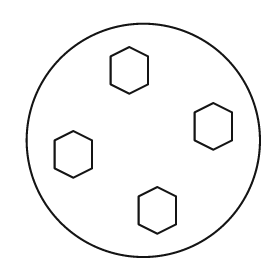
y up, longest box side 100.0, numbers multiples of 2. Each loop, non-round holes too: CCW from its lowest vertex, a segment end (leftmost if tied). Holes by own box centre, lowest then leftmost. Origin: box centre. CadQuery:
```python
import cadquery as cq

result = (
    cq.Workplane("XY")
    .moveTo(0.0, 0.0)
    .circle(50.0)
    .moveTo(6.0, -40.0)
    .lineTo(14.0, -36.0)
    .lineTo(14.0, -24.0)
    .lineTo(6.0, -20.0)
    .lineTo(-2.0, -24.0)
    .lineTo(-2.0, -36.0)
    .close()
    .moveTo(-30.0, -16.0)
    .lineTo(-22.0, -12.0)
    .lineTo(-22.0, 0.0)
    .lineTo(-30.0, 4.0)
    .lineTo(-38.0, 0.0)
    .lineTo(-38.0, -12.0)
    .close()
    .moveTo(30.0, -4.0)
    .lineTo(38.0, 0.0)
    .lineTo(38.0, 12.0)
    .lineTo(30.0, 16.0)
    .lineTo(22.0, 12.0)
    .lineTo(22.0, 0.0)
    .close()
    .moveTo(-6.0, 20.0)
    .lineTo(2.0, 24.0)
    .lineTo(2.0, 36.0)
    .lineTo(-6.0, 40.0)
    .lineTo(-14.0, 36.0)
    .lineTo(-14.0, 24.0)
    .close()
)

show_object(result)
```